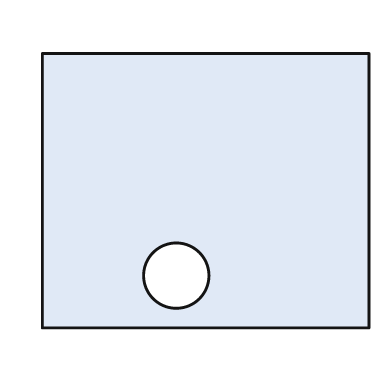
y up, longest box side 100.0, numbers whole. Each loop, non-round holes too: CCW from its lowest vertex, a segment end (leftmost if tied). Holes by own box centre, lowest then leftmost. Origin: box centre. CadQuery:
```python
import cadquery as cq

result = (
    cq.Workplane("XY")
    .moveTo(-50.0, -42.0)
    .lineTo(50.0, -42.0)
    .lineTo(50.0, 42.0)
    .lineTo(-50.0, 42.0)
    .close()
    .moveTo(-9.0, -26.0)
    .circle(10.0)
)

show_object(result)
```